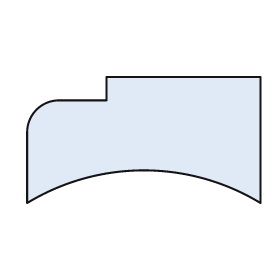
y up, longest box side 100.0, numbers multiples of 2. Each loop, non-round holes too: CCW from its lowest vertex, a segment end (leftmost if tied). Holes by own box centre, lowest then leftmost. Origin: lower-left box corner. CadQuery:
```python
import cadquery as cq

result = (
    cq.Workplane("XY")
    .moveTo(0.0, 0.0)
    .threePointArc((50.0, 14.0), (100.0, 0.0))
    .lineTo(100.0, 54.0)
    .lineTo(34.0, 54.0)
    .lineTo(34.0, 44.0)
    .lineTo(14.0, 44.0)
    .threePointArc((4.0, 40.0), (0.0, 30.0))
    .close()
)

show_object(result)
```